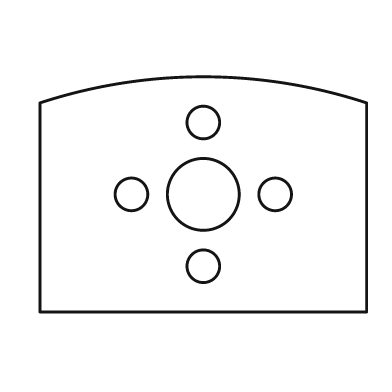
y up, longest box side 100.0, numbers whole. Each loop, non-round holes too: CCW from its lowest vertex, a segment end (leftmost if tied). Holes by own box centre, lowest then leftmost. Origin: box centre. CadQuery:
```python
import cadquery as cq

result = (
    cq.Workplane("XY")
    .moveTo(-50.0, -36.0)
    .lineTo(50.0, -36.0)
    .lineTo(50.0, 28.0)
    .threePointArc((0.0, 36.0), (-50.0, 28.0))
    .close()
    .moveTo(0.0, -22.0)
    .circle(5.0)
    .moveTo(-22.0, 0.0)
    .circle(5.0)
    .moveTo(0.0, 0.0)
    .circle(11.0)
    .moveTo(22.0, 0.0)
    .circle(5.0)
    .moveTo(0.0, 22.0)
    .circle(5.0)
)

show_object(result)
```